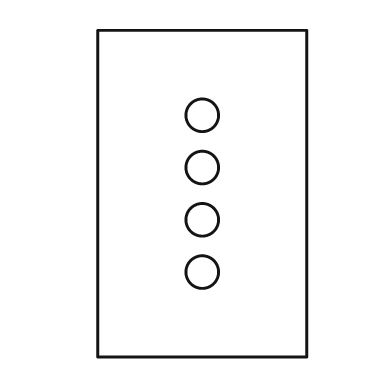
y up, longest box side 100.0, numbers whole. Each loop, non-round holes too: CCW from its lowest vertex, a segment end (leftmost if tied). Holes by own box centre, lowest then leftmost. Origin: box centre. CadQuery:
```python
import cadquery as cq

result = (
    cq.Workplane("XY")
    .moveTo(-32.0, -50.0)
    .lineTo(32.0, -50.0)
    .lineTo(32.0, 50.0)
    .lineTo(-32.0, 50.0)
    .close()
    .moveTo(0.0, -24.0)
    .circle(5.0)
    .moveTo(0.0, -8.0)
    .circle(5.0)
    .moveTo(0.0, 8.0)
    .circle(5.0)
    .moveTo(0.0, 24.0)
    .circle(5.0)
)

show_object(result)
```